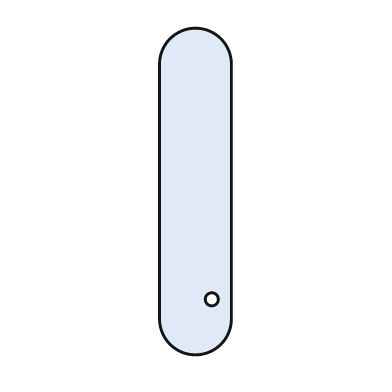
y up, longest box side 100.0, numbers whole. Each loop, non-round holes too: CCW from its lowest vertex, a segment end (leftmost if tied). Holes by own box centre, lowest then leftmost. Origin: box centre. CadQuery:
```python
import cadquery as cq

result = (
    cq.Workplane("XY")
    .moveTo(-11.0, -39.0)
    .threePointArc((0.0, -50.0), (11.0, -39.0))
    .lineTo(11.0, 39.0)
    .threePointArc((0.0, 50.0), (-11.0, 39.0))
    .close()
    .moveTo(5.0, -33.0)
    .circle(2.0)
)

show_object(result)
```